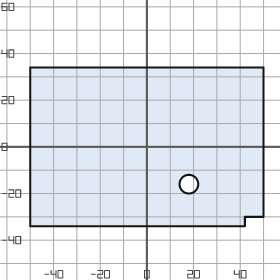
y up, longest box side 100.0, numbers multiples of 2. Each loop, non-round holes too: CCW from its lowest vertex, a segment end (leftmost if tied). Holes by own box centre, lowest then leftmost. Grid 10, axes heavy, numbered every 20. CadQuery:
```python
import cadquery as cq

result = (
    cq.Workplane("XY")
    .moveTo(-50.0, -34.0)
    .lineTo(42.0, -34.0)
    .lineTo(42.0, -30.0)
    .lineTo(50.0, -30.0)
    .lineTo(50.0, 34.0)
    .lineTo(-50.0, 34.0)
    .close()
    .moveTo(18.0, -16.0)
    .circle(4.0)
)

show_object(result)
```